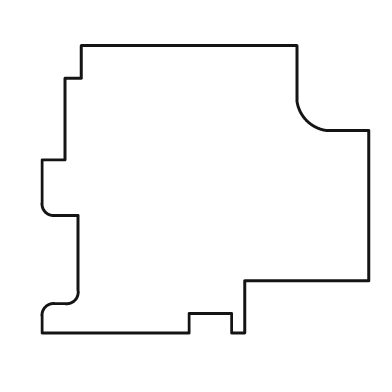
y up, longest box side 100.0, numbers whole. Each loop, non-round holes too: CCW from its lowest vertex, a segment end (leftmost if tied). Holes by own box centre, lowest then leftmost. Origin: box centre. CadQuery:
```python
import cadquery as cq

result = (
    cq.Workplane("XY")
    .moveTo(-50.0, -44.0)
    .lineTo(-5.0, -44.0)
    .lineTo(-5.0, -38.0)
    .lineTo(8.0, -38.0)
    .lineTo(8.0, -44.0)
    .lineTo(12.0, -44.0)
    .lineTo(12.0, -28.0)
    .lineTo(50.0, -28.0)
    .lineTo(50.0, 18.0)
    .lineTo(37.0, 18.0)
    .threePointArc((31.0, 21.0), (28.0, 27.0))
    .lineTo(28.0, 44.0)
    .lineTo(-38.0, 44.0)
    .lineTo(-38.0, 34.0)
    .lineTo(-43.0, 34.0)
    .lineTo(-43.0, 9.0)
    .lineTo(-50.0, 9.0)
    .lineTo(-50.0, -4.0)
    .threePointArc((-49.0, -7.0), (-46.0, -8.0))
    .lineTo(-39.0, -8.0)
    .lineTo(-39.0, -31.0)
    .threePointArc((-40.0, -34.0), (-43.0, -35.0))
    .lineTo(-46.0, -35.0)
    .threePointArc((-49.0, -36.0), (-50.0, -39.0))
    .close()
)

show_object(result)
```